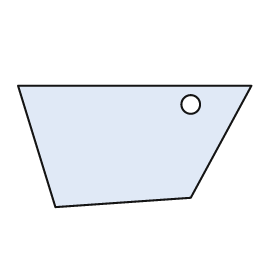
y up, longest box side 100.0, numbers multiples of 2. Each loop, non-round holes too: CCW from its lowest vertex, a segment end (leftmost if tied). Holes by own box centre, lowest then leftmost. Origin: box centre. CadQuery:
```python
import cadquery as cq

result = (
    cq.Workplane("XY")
    .moveTo(-34.0, -26.0)
    .lineTo(24.0, -22.0)
    .lineTo(50.0, 26.0)
    .lineTo(-50.0, 26.0)
    .close()
    .moveTo(24.0, 18.0)
    .circle(4.0)
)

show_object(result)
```